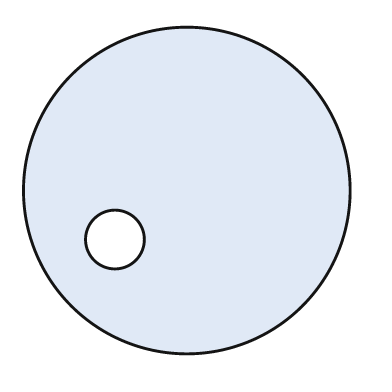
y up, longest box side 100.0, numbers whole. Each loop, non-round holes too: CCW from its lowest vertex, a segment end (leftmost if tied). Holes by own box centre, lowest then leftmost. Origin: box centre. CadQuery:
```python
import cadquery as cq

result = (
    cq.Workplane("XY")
    .moveTo(0.0, 0.0)
    .circle(50.0)
    .moveTo(-22.0, -15.0)
    .circle(9.0)
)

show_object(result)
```